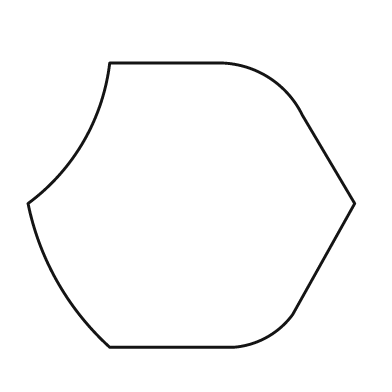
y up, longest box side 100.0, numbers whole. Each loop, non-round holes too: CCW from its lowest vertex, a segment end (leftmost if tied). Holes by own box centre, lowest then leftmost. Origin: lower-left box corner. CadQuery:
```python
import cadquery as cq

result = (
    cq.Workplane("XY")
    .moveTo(25.0, 0.0)
    .lineTo(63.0, 0.0)
    .threePointArc((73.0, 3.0), (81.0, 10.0))
    .lineTo(100.0, 44.0)
    .lineTo(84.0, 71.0)
    .threePointArc((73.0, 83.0), (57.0, 87.0))
    .lineTo(25.0, 87.0)
    .threePointArc((17.0, 63.0), (0.0, 44.0))
    .threePointArc((9.0, 20.0), (25.0, 0.0))
    .close()
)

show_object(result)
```